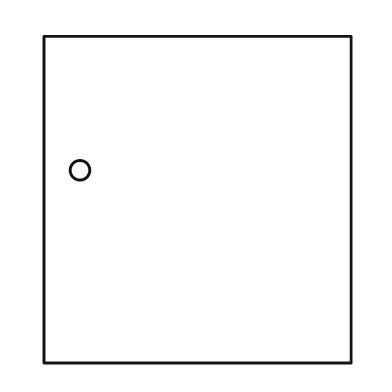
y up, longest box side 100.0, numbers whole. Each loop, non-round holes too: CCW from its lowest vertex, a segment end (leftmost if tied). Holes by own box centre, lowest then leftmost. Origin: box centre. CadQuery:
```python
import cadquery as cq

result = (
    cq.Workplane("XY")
    .moveTo(-47.0, -50.0)
    .lineTo(47.0, -50.0)
    .lineTo(47.0, 50.0)
    .lineTo(-47.0, 50.0)
    .close()
    .moveTo(-36.0, 9.0)
    .circle(3.0)
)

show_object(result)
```